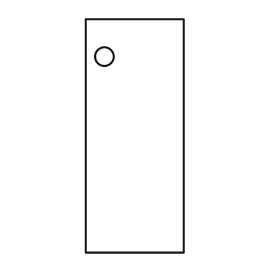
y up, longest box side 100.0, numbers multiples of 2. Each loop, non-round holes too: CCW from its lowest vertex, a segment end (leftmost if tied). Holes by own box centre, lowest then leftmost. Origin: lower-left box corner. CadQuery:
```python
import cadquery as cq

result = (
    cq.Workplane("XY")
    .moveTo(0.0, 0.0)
    .lineTo(42.0, 0.0)
    .lineTo(42.0, 100.0)
    .lineTo(0.0, 100.0)
    .close()
    .moveTo(8.0, 84.0)
    .circle(4.0)
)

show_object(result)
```